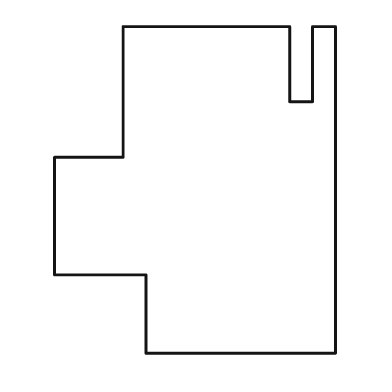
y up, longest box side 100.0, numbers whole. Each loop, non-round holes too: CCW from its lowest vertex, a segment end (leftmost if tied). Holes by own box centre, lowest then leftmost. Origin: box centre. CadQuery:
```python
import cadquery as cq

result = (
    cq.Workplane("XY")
    .moveTo(-15.0, -50.0)
    .lineTo(43.0, -50.0)
    .lineTo(43.0, 50.0)
    .lineTo(36.0, 50.0)
    .lineTo(36.0, 27.0)
    .lineTo(29.0, 27.0)
    .lineTo(29.0, 50.0)
    .lineTo(-22.0, 50.0)
    .lineTo(-22.0, 10.0)
    .lineTo(-43.0, 10.0)
    .lineTo(-43.0, -26.0)
    .lineTo(-15.0, -26.0)
    .close()
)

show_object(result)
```